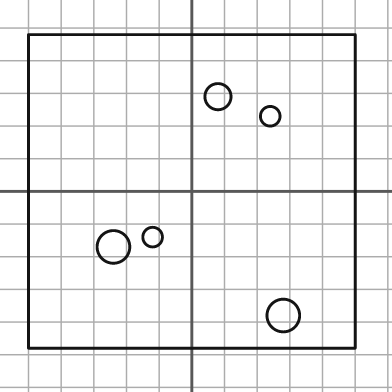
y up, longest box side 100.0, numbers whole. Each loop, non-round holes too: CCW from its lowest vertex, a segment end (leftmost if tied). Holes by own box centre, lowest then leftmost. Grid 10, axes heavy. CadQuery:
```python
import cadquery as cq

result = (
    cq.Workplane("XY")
    .moveTo(-50.0, -48.0)
    .lineTo(50.0, -48.0)
    .lineTo(50.0, 48.0)
    .lineTo(-50.0, 48.0)
    .close()
    .moveTo(28.0, -38.0)
    .circle(5.0)
    .moveTo(-24.0, -17.0)
    .circle(5.0)
    .moveTo(-12.0, -14.0)
    .circle(3.0)
    .moveTo(24.0, 23.0)
    .circle(3.0)
    .moveTo(8.0, 29.0)
    .circle(4.0)
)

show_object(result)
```